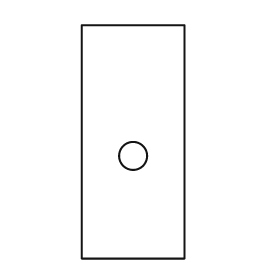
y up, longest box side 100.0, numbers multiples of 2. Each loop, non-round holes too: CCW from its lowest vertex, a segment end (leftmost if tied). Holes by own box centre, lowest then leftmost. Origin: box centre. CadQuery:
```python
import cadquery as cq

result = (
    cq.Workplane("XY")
    .moveTo(-22.0, -50.0)
    .lineTo(22.0, -50.0)
    .lineTo(22.0, 50.0)
    .lineTo(-22.0, 50.0)
    .close()
    .moveTo(0.0, -6.0)
    .circle(6.0)
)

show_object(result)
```